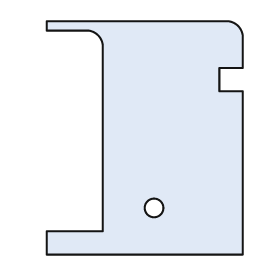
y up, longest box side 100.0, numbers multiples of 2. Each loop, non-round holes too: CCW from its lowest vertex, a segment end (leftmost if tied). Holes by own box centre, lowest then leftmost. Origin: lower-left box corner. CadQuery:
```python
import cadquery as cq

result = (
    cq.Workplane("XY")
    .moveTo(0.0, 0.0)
    .lineTo(84.0, 0.0)
    .lineTo(84.0, 70.0)
    .lineTo(74.0, 70.0)
    .lineTo(74.0, 80.0)
    .lineTo(84.0, 80.0)
    .lineTo(84.0, 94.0)
    .threePointArc((82.0, 98.0), (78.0, 100.0))
    .lineTo(0.0, 100.0)
    .lineTo(0.0, 96.0)
    .lineTo(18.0, 96.0)
    .threePointArc((22.0, 94.0), (24.0, 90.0))
    .lineTo(24.0, 10.0)
    .lineTo(0.0, 10.0)
    .close()
    .moveTo(46.0, 20.0)
    .circle(4.0)
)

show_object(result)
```